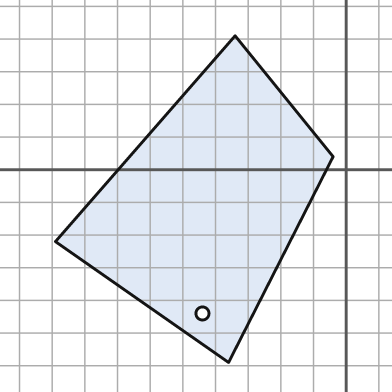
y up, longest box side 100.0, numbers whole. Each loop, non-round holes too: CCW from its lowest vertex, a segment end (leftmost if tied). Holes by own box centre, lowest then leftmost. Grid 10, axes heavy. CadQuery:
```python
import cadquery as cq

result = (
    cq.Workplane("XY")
    .moveTo(-36.0, -59.0)
    .lineTo(-4.0, 4.0)
    .lineTo(-34.0, 41.0)
    .lineTo(-89.0, -22.0)
    .close()
    .moveTo(-44.0, -44.0)
    .circle(2.0)
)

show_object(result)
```